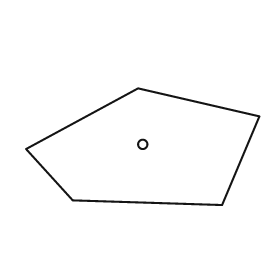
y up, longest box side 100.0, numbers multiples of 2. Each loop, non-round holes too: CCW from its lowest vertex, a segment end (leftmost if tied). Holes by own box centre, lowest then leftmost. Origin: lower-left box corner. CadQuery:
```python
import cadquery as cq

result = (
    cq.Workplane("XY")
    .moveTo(84.0, 0.0)
    .lineTo(100.0, 38.0)
    .lineTo(48.0, 50.0)
    .lineTo(0.0, 24.0)
    .lineTo(20.0, 2.0)
    .close()
    .moveTo(50.0, 26.0)
    .circle(2.0)
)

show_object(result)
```